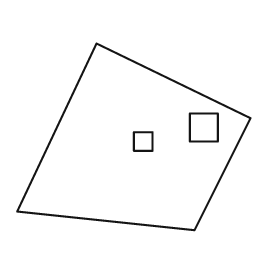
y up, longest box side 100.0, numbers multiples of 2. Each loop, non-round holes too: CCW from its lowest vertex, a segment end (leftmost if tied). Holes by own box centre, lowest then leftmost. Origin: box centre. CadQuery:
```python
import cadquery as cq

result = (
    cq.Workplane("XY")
    .moveTo(26.0, -40.0)
    .lineTo(50.0, 8.0)
    .lineTo(-16.0, 40.0)
    .lineTo(-50.0, -32.0)
    .close()
    .moveTo(0.0, -6.0)
    .lineTo(8.0, -6.0)
    .lineTo(8.0, 2.0)
    .lineTo(0.0, 2.0)
    .close()
    .moveTo(24.0, -2.0)
    .lineTo(36.0, -2.0)
    .lineTo(36.0, 10.0)
    .lineTo(24.0, 10.0)
    .close()
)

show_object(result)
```